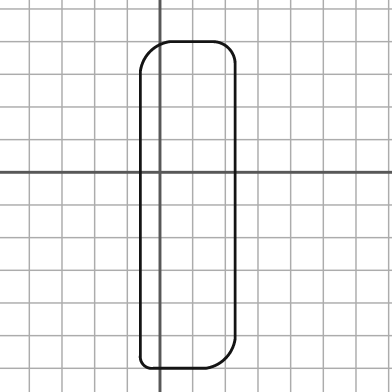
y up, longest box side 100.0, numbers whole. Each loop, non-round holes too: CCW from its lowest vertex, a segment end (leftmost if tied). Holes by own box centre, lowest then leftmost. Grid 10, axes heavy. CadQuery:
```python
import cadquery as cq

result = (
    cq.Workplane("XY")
    .moveTo(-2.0, -60.0)
    .lineTo(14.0, -60.0)
    .threePointArc((20.0, -57.0), (23.0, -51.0))
    .lineTo(23.0, 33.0)
    .threePointArc((21.0, 38.0), (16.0, 40.0))
    .lineTo(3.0, 40.0)
    .threePointArc((-3.0, 37.0), (-6.0, 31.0))
    .lineTo(-6.0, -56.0)
    .threePointArc((-5.0, -59.0), (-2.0, -60.0))
    .close()
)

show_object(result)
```